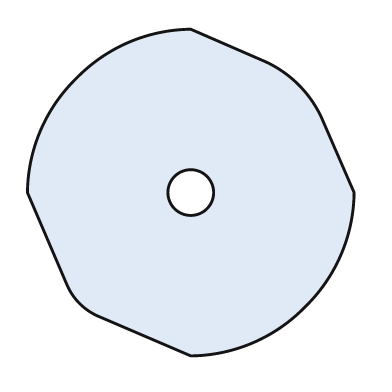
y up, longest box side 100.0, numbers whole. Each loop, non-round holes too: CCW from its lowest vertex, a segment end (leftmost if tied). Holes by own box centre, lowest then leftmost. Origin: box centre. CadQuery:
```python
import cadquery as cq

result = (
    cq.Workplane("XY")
    .moveTo(0.0, -50.0)
    .threePointArc((19.0, -46.0), (35.0, -35.0))
    .threePointArc((46.0, -19.0), (50.0, 0.0))
    .lineTo(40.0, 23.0)
    .threePointArc((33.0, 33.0), (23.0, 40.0))
    .lineTo(0.0, 50.0)
    .threePointArc((-19.0, 46.0), (-35.0, 35.0))
    .threePointArc((-46.0, 19.0), (-50.0, 0.0))
    .lineTo(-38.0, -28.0)
    .threePointArc((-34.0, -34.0), (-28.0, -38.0))
    .close()
    .moveTo(0.0, 0.0)
    .circle(7.0)
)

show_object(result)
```